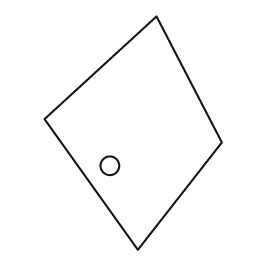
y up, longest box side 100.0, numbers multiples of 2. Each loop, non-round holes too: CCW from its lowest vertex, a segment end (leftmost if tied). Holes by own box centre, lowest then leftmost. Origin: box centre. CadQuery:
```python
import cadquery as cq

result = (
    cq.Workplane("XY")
    .moveTo(2.0, -50.0)
    .lineTo(38.0, -4.0)
    .lineTo(10.0, 50.0)
    .lineTo(-38.0, 6.0)
    .close()
    .moveTo(-10.0, -14.0)
    .circle(4.0)
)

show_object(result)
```